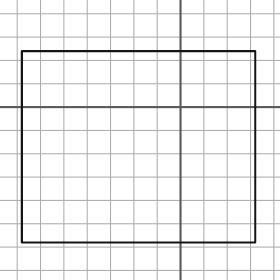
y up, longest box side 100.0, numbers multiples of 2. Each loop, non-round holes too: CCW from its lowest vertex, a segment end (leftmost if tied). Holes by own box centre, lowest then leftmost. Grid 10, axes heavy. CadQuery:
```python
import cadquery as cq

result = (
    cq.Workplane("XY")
    .moveTo(-68.0, -58.0)
    .lineTo(32.0, -58.0)
    .lineTo(32.0, 24.0)
    .lineTo(-68.0, 24.0)
    .close()
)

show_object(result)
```